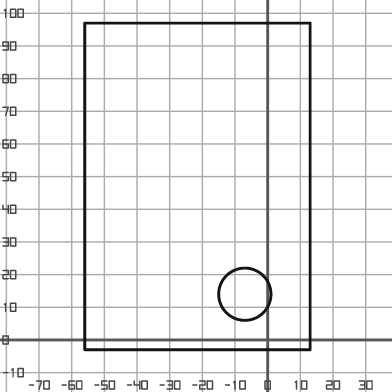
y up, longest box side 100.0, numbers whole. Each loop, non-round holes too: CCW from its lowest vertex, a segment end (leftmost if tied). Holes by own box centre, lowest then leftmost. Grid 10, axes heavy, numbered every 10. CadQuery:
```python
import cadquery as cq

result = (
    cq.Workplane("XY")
    .moveTo(-56.0, -3.0)
    .lineTo(13.0, -3.0)
    .lineTo(13.0, 97.0)
    .lineTo(-56.0, 97.0)
    .close()
    .moveTo(-7.0, 14.0)
    .circle(8.0)
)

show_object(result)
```